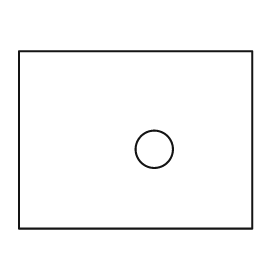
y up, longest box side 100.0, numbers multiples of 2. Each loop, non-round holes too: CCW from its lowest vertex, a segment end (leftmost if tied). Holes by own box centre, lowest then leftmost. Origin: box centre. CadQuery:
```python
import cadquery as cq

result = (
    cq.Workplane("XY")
    .moveTo(-50.0, -38.0)
    .lineTo(50.0, -38.0)
    .lineTo(50.0, 38.0)
    .lineTo(-50.0, 38.0)
    .close()
    .moveTo(8.0, -4.0)
    .circle(8.0)
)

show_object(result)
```